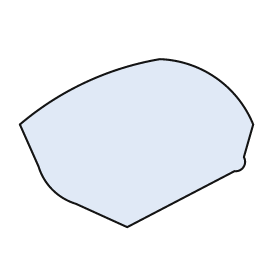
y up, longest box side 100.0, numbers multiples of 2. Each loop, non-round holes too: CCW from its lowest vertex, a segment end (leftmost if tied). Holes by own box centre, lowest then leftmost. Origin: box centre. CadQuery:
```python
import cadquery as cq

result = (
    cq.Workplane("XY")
    .moveTo(-4.0, -36.0)
    .lineTo(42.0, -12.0)
    .threePointArc((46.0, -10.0), (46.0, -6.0))
    .lineTo(50.0, 8.0)
    .threePointArc((34.0, 28.0), (10.0, 36.0))
    .threePointArc((-22.0, 26.0), (-50.0, 8.0))
    .lineTo(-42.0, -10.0)
    .threePointArc((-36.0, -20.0), (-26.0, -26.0))
    .close()
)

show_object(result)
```